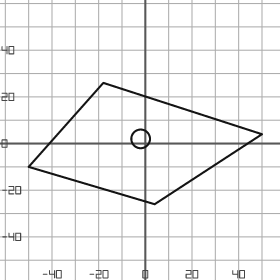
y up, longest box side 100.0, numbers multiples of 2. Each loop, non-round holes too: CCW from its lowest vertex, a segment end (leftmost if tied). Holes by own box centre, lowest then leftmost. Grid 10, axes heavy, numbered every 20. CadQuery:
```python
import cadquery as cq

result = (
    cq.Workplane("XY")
    .moveTo(4.0, -26.0)
    .lineTo(50.0, 4.0)
    .lineTo(-18.0, 26.0)
    .lineTo(-50.0, -10.0)
    .close()
    .moveTo(-2.0, 2.0)
    .circle(4.0)
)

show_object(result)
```